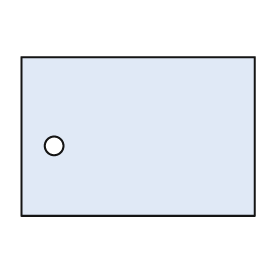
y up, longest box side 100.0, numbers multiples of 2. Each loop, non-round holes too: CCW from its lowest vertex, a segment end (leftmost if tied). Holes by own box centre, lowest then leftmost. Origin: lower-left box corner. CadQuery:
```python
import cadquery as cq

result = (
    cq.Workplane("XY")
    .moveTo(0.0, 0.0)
    .lineTo(100.0, 0.0)
    .lineTo(100.0, 68.0)
    .lineTo(0.0, 68.0)
    .close()
    .moveTo(14.0, 30.0)
    .circle(4.0)
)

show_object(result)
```